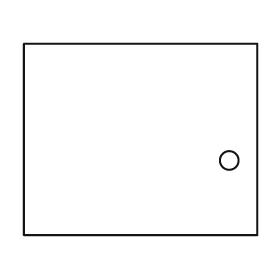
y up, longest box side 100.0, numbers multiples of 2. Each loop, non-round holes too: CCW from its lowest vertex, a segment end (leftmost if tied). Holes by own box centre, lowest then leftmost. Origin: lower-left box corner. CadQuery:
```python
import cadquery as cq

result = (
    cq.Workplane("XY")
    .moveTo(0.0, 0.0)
    .lineTo(100.0, 0.0)
    .lineTo(100.0, 82.0)
    .lineTo(0.0, 82.0)
    .close()
    .moveTo(88.0, 32.0)
    .circle(4.0)
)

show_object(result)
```